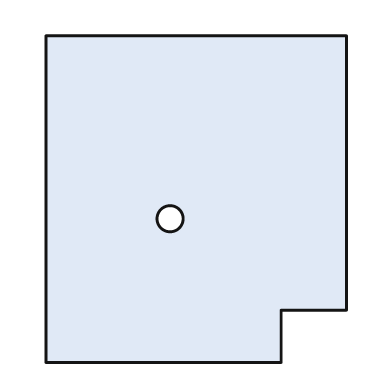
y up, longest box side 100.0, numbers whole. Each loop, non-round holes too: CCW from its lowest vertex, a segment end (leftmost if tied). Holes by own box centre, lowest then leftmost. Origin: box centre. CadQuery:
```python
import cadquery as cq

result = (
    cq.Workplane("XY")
    .moveTo(-46.0, -50.0)
    .lineTo(26.0, -50.0)
    .lineTo(26.0, -34.0)
    .lineTo(46.0, -34.0)
    .lineTo(46.0, 50.0)
    .lineTo(-46.0, 50.0)
    .close()
    .moveTo(-8.0, -6.0)
    .circle(4.0)
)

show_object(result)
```